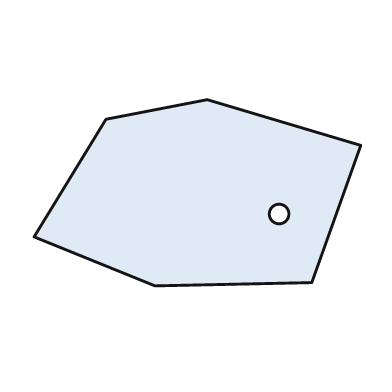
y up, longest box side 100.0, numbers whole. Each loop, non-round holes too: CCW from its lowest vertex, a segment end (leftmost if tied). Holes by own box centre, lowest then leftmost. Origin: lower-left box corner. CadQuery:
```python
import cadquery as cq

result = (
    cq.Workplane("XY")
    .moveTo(37.0, 0.0)
    .lineTo(85.0, 1.0)
    .lineTo(100.0, 43.0)
    .lineTo(53.0, 57.0)
    .lineTo(22.0, 51.0)
    .lineTo(0.0, 15.0)
    .close()
    .moveTo(75.0, 22.0)
    .circle(3.0)
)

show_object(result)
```